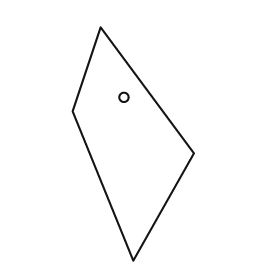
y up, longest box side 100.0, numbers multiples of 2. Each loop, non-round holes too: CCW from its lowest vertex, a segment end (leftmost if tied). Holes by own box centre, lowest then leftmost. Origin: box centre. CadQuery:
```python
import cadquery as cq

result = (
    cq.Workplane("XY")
    .moveTo(0.0, -50.0)
    .lineTo(26.0, -4.0)
    .lineTo(-14.0, 50.0)
    .lineTo(-26.0, 14.0)
    .close()
    .moveTo(-4.0, 20.0)
    .circle(2.0)
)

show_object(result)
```